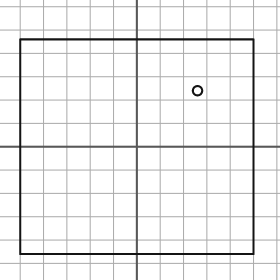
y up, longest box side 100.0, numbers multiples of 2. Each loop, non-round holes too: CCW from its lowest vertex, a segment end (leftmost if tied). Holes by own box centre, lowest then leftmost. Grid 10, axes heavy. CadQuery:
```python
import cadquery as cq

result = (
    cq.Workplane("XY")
    .moveTo(-50.0, -46.0)
    .lineTo(50.0, -46.0)
    .lineTo(50.0, 46.0)
    .lineTo(-50.0, 46.0)
    .close()
    .moveTo(26.0, 24.0)
    .circle(2.0)
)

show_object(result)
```